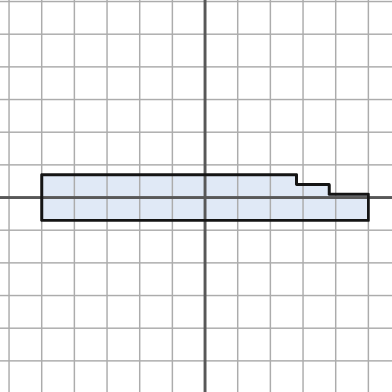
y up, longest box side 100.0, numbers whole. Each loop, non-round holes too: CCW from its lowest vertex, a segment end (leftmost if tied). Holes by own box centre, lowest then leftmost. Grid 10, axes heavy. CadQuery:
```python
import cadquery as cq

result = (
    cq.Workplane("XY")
    .moveTo(-50.0, -7.0)
    .lineTo(50.0, -7.0)
    .lineTo(50.0, 1.0)
    .lineTo(38.0, 1.0)
    .lineTo(38.0, 4.0)
    .lineTo(28.0, 4.0)
    .lineTo(28.0, 7.0)
    .lineTo(-50.0, 7.0)
    .close()
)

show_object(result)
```